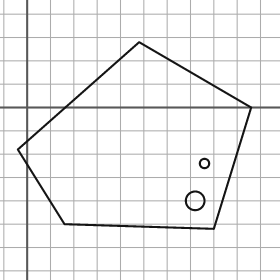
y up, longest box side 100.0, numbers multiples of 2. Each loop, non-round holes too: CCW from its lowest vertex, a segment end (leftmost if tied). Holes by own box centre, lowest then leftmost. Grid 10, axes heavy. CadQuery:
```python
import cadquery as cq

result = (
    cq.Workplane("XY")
    .moveTo(80.0, -52.0)
    .lineTo(96.0, 0.0)
    .lineTo(48.0, 28.0)
    .lineTo(-4.0, -18.0)
    .lineTo(16.0, -50.0)
    .close()
    .moveTo(72.0, -40.0)
    .circle(4.0)
    .moveTo(76.0, -24.0)
    .circle(2.0)
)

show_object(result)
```